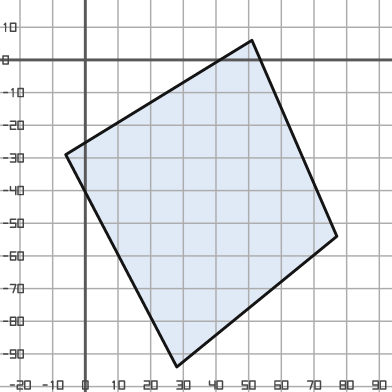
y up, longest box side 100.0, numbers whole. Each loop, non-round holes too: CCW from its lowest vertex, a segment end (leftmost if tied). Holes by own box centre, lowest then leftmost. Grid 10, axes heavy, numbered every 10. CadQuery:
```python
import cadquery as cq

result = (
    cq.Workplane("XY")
    .moveTo(28.0, -94.0)
    .lineTo(77.0, -54.0)
    .lineTo(51.0, 6.0)
    .lineTo(-6.0, -29.0)
    .close()
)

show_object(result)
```